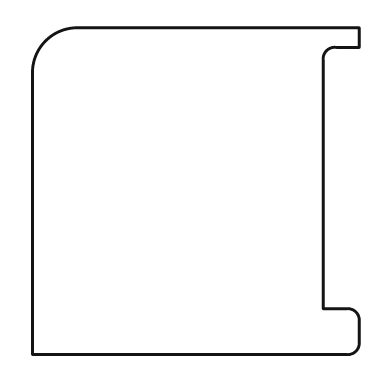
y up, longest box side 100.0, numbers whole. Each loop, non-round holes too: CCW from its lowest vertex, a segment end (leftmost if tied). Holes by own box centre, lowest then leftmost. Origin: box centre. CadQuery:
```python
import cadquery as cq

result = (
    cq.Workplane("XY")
    .moveTo(-50.0, -50.0)
    .lineTo(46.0, -50.0)
    .threePointArc((49.0, -49.0), (50.0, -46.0))
    .lineTo(50.0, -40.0)
    .threePointArc((49.0, -37.0), (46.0, -36.0))
    .lineTo(39.0, -36.0)
    .lineTo(39.0, 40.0)
    .threePointArc((40.0, 43.0), (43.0, 44.0))
    .lineTo(50.0, 44.0)
    .lineTo(50.0, 50.0)
    .lineTo(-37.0, 50.0)
    .threePointArc((-46.0, 46.0), (-50.0, 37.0))
    .close()
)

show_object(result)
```